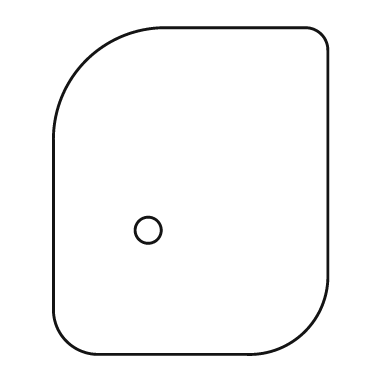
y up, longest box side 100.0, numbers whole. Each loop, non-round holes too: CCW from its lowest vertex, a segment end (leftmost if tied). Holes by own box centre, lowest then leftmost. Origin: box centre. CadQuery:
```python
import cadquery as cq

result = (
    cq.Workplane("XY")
    .moveTo(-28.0, -50.0)
    .lineTo(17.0, -50.0)
    .threePointArc((35.0, -43.0), (42.0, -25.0))
    .lineTo(42.0, 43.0)
    .threePointArc((40.0, 48.0), (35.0, 50.0))
    .lineTo(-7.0, 50.0)
    .threePointArc((-32.0, 40.0), (-42.0, 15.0))
    .lineTo(-42.0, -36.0)
    .threePointArc((-38.0, -46.0), (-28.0, -50.0))
    .close()
    .moveTo(-13.0, -12.0)
    .circle(4.0)
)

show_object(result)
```